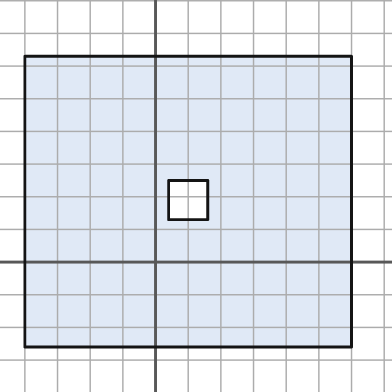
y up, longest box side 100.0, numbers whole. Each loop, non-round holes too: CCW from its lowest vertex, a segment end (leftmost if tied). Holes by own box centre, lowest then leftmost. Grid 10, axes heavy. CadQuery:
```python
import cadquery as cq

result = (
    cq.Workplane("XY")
    .moveTo(-40.0, -26.0)
    .lineTo(60.0, -26.0)
    .lineTo(60.0, 63.0)
    .lineTo(-40.0, 63.0)
    .close()
    .moveTo(4.0, 13.0)
    .lineTo(16.0, 13.0)
    .lineTo(16.0, 25.0)
    .lineTo(4.0, 25.0)
    .close()
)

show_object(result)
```